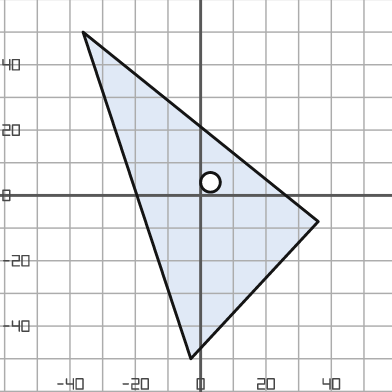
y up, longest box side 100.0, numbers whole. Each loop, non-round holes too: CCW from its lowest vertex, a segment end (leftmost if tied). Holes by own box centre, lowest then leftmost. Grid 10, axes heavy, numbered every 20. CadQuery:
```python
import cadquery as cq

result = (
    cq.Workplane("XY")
    .moveTo(-3.0, -50.0)
    .lineTo(36.0, -8.0)
    .lineTo(-36.0, 50.0)
    .close()
    .moveTo(3.0, 4.0)
    .circle(3.0)
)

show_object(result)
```